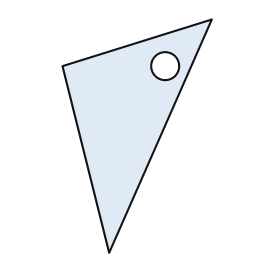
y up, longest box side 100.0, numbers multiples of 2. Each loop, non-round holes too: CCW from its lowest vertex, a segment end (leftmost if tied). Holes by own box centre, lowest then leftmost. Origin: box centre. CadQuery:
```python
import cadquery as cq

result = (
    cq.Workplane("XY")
    .moveTo(-12.0, -50.0)
    .lineTo(32.0, 50.0)
    .lineTo(-32.0, 30.0)
    .close()
    .moveTo(12.0, 30.0)
    .circle(6.0)
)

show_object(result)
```